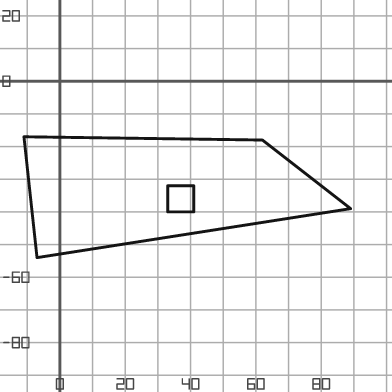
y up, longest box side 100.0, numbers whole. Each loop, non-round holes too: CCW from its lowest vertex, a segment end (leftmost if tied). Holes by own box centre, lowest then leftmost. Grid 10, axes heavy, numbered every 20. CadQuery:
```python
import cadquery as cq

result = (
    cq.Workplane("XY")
    .moveTo(-7.0, -54.0)
    .lineTo(89.0, -39.0)
    .lineTo(62.0, -18.0)
    .lineTo(-11.0, -17.0)
    .close()
    .moveTo(33.0, -40.0)
    .lineTo(41.0, -40.0)
    .lineTo(41.0, -32.0)
    .lineTo(33.0, -32.0)
    .close()
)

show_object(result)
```